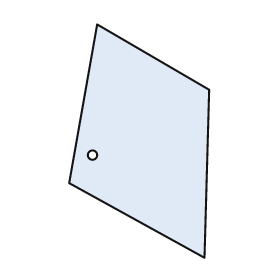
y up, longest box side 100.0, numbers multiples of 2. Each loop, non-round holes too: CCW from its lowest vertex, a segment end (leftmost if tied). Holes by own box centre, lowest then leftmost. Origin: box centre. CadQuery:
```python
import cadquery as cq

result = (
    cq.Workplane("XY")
    .moveTo(28.0, -50.0)
    .lineTo(30.0, 22.0)
    .lineTo(-18.0, 50.0)
    .lineTo(-30.0, -18.0)
    .close()
    .moveTo(-20.0, -6.0)
    .circle(2.0)
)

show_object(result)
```